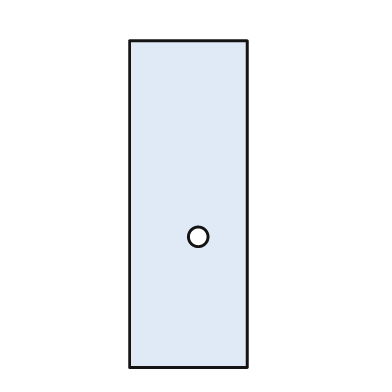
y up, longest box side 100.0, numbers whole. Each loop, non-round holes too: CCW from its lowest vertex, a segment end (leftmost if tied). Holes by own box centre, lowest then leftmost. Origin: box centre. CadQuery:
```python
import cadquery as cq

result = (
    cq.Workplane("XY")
    .moveTo(-18.0, -50.0)
    .lineTo(18.0, -50.0)
    .lineTo(18.0, 50.0)
    .lineTo(-18.0, 50.0)
    .close()
    .moveTo(3.0, -10.0)
    .circle(3.0)
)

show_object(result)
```